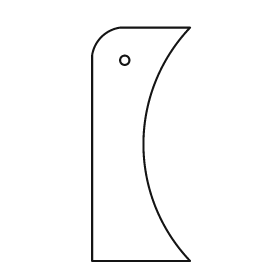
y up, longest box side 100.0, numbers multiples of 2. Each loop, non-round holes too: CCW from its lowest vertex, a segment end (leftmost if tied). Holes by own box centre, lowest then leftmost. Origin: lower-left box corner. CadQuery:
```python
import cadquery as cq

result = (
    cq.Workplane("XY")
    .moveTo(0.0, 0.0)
    .lineTo(42.0, 0.0)
    .threePointArc((22.0, 50.0), (42.0, 100.0))
    .lineTo(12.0, 100.0)
    .threePointArc((4.0, 96.0), (0.0, 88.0))
    .close()
    .moveTo(14.0, 86.0)
    .circle(2.0)
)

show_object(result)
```